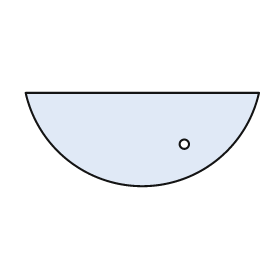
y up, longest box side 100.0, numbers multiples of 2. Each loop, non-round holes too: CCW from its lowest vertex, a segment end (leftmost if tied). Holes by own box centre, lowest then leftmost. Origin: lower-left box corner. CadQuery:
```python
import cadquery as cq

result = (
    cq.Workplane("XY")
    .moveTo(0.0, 40.0)
    .threePointArc((50.0, 0.0), (100.0, 40.0))
    .close()
    .moveTo(68.0, 18.0)
    .circle(2.0)
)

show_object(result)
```